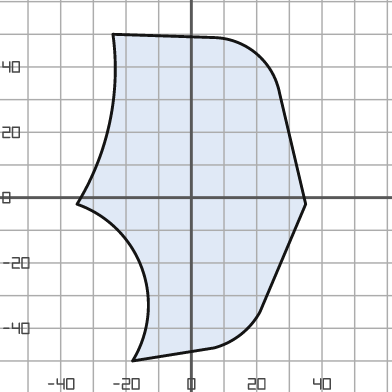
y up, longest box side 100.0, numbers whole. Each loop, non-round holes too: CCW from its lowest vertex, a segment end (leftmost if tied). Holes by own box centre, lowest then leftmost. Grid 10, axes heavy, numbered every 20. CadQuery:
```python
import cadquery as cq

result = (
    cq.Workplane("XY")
    .moveTo(-18.0, -50.0)
    .lineTo(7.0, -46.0)
    .threePointArc((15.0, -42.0), (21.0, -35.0))
    .lineTo(35.0, -2.0)
    .lineTo(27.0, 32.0)
    .threePointArc((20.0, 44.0), (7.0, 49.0))
    .lineTo(-24.0, 50.0)
    .threePointArc((-25.0, 23.0), (-35.0, -2.0))
    .threePointArc((-15.0, -22.0), (-18.0, -50.0))
    .close()
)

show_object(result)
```